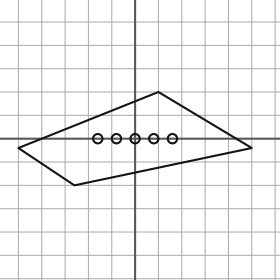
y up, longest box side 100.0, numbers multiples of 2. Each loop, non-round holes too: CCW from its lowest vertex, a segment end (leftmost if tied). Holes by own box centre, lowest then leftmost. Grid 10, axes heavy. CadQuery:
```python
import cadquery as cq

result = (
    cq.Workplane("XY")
    .moveTo(-26.0, -20.0)
    .lineTo(50.0, -4.0)
    .lineTo(10.0, 20.0)
    .lineTo(-50.0, -4.0)
    .close()
    .moveTo(-16.0, 0.0)
    .circle(2.0)
    .moveTo(-8.0, 0.0)
    .circle(2.0)
    .moveTo(0.0, 0.0)
    .circle(2.0)
    .moveTo(8.0, 0.0)
    .circle(2.0)
    .moveTo(16.0, 0.0)
    .circle(2.0)
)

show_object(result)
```